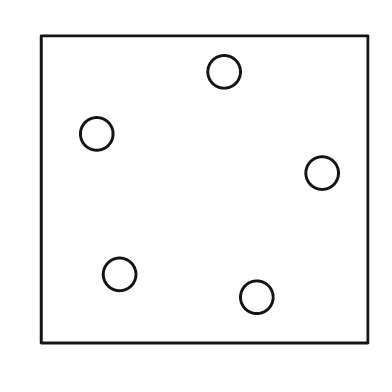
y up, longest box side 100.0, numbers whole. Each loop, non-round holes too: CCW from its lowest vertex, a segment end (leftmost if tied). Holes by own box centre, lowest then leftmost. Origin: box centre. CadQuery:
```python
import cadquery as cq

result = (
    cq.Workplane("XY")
    .moveTo(-50.0, -47.0)
    .lineTo(50.0, -47.0)
    .lineTo(50.0, 47.0)
    .lineTo(-50.0, 47.0)
    .close()
    .moveTo(16.0, -33.0)
    .circle(5.0)
    .moveTo(-26.0, -26.0)
    .circle(5.0)
    .moveTo(36.0, 5.0)
    .circle(5.0)
    .moveTo(-33.0, 17.0)
    .circle(5.0)
    .moveTo(6.0, 36.0)
    .circle(5.0)
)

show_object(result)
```